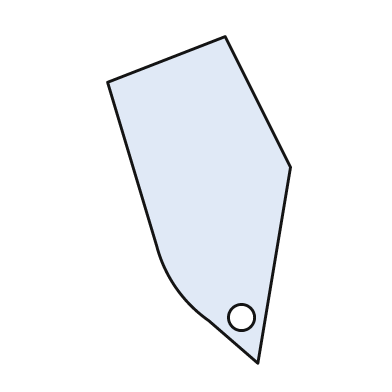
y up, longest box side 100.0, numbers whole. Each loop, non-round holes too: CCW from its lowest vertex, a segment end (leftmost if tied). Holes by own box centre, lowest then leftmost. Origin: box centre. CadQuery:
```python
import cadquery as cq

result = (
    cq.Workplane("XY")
    .moveTo(18.0, -50.0)
    .lineTo(28.0, 10.0)
    .lineTo(8.0, 50.0)
    .lineTo(-28.0, 36.0)
    .lineTo(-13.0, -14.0)
    .threePointArc((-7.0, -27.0), (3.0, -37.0))
    .close()
    .moveTo(13.0, -36.0)
    .circle(4.0)
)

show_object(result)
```